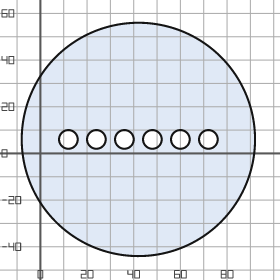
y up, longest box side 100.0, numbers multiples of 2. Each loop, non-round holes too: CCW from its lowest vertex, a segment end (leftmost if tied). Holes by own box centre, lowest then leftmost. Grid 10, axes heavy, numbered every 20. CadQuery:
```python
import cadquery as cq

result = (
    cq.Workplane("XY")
    .moveTo(42.0, 6.0)
    .circle(50.0)
    .moveTo(12.0, 6.0)
    .circle(4.0)
    .moveTo(24.0, 6.0)
    .circle(4.0)
    .moveTo(36.0, 6.0)
    .circle(4.0)
    .moveTo(48.0, 6.0)
    .circle(4.0)
    .moveTo(60.0, 6.0)
    .circle(4.0)
    .moveTo(72.0, 6.0)
    .circle(4.0)
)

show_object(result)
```